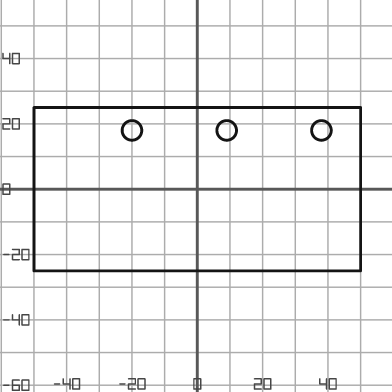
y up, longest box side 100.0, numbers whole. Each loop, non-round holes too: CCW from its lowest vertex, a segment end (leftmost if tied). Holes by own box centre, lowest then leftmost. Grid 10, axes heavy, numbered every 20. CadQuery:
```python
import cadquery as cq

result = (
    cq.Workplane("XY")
    .moveTo(-50.0, -25.0)
    .lineTo(50.0, -25.0)
    .lineTo(50.0, 25.0)
    .lineTo(-50.0, 25.0)
    .close()
    .moveTo(-20.0, 18.0)
    .circle(3.0)
    .moveTo(9.0, 18.0)
    .circle(3.0)
    .moveTo(38.0, 18.0)
    .circle(3.0)
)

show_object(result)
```